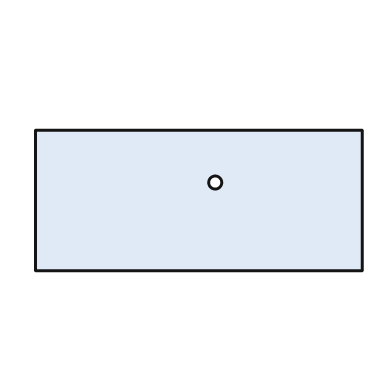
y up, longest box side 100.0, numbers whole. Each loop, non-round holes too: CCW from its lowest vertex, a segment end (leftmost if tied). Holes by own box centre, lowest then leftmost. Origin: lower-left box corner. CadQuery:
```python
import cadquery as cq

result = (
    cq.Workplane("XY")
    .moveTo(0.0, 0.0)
    .lineTo(100.0, 0.0)
    .lineTo(100.0, 43.0)
    .lineTo(0.0, 43.0)
    .close()
    .moveTo(55.0, 27.0)
    .circle(2.0)
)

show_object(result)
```